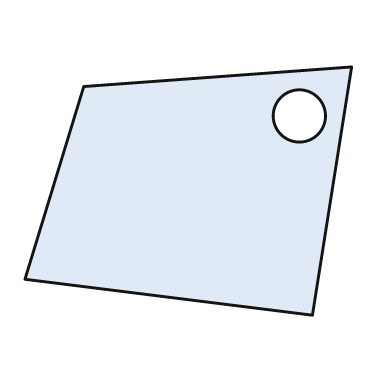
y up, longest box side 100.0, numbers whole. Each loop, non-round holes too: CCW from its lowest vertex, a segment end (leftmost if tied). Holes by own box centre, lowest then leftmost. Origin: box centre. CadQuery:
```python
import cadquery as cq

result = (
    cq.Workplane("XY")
    .moveTo(38.0, -38.0)
    .lineTo(50.0, 38.0)
    .lineTo(-32.0, 32.0)
    .lineTo(-50.0, -27.0)
    .close()
    .moveTo(34.0, 23.0)
    .circle(8.0)
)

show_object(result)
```